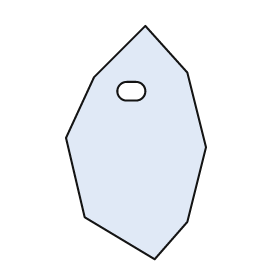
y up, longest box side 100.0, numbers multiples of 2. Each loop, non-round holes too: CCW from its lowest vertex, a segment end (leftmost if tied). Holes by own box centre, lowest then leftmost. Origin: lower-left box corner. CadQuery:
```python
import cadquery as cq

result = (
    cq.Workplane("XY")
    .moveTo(38.0, 0.0)
    .lineTo(52.0, 16.0)
    .lineTo(60.0, 48.0)
    .lineTo(52.0, 80.0)
    .lineTo(34.0, 100.0)
    .lineTo(12.0, 78.0)
    .lineTo(0.0, 52.0)
    .lineTo(8.0, 18.0)
    .close()
    .moveTo(26.0, 68.0)
    .lineTo(30.0, 68.0)
    .threePointArc((34.0, 72.0), (30.0, 76.0))
    .lineTo(26.0, 76.0)
    .threePointArc((22.0, 72.0), (26.0, 68.0))
    .close()
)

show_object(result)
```